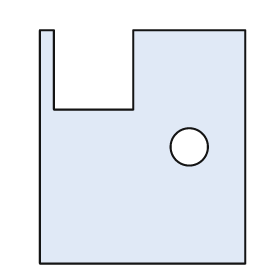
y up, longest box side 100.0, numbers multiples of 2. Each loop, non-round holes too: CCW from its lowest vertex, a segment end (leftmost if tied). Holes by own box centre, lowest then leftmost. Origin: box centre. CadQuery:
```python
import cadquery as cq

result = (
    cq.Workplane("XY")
    .moveTo(-44.0, -50.0)
    .lineTo(44.0, -50.0)
    .lineTo(44.0, 50.0)
    .lineTo(-4.0, 50.0)
    .lineTo(-4.0, 16.0)
    .lineTo(-38.0, 16.0)
    .lineTo(-38.0, 50.0)
    .lineTo(-44.0, 50.0)
    .close()
    .moveTo(20.0, 0.0)
    .circle(8.0)
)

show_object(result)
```